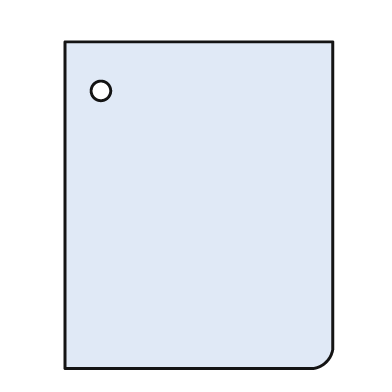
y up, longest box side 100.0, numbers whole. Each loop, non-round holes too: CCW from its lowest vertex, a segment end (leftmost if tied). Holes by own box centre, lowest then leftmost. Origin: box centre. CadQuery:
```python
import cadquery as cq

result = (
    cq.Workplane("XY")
    .moveTo(-41.0, -50.0)
    .lineTo(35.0, -50.0)
    .threePointArc((39.0, -48.0), (41.0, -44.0))
    .lineTo(41.0, 50.0)
    .lineTo(-41.0, 50.0)
    .close()
    .moveTo(-30.0, 35.0)
    .circle(3.0)
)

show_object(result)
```